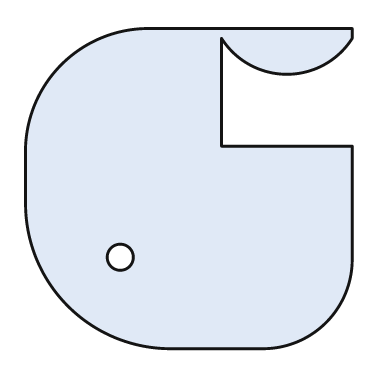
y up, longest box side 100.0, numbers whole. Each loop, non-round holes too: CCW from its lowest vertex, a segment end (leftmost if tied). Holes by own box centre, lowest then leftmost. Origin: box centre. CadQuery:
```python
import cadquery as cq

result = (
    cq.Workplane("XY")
    .moveTo(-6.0, -49.0)
    .lineTo(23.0, -49.0)
    .threePointArc((42.0, -41.0), (50.0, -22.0))
    .lineTo(50.0, 13.0)
    .lineTo(10.0, 13.0)
    .lineTo(10.0, 46.0)
    .threePointArc((30.0, 35.0), (50.0, 46.0))
    .lineTo(50.0, 49.0)
    .lineTo(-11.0, 49.0)
    .threePointArc((-39.0, 38.0), (-50.0, 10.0))
    .lineTo(-50.0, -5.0)
    .threePointArc((-37.0, -36.0), (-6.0, -49.0))
    .close()
    .moveTo(-21.0, -21.0)
    .circle(4.0)
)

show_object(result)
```